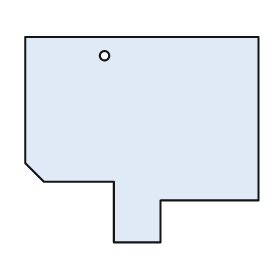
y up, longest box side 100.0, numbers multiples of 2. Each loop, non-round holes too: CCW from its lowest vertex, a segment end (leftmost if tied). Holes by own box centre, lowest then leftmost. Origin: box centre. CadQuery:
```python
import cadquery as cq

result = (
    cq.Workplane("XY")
    .moveTo(-12.0, -44.0)
    .lineTo(8.0, -44.0)
    .lineTo(8.0, -26.0)
    .lineTo(50.0, -26.0)
    .lineTo(50.0, 44.0)
    .lineTo(-50.0, 44.0)
    .lineTo(-50.0, -10.0)
    .lineTo(-42.0, -18.0)
    .lineTo(-12.0, -18.0)
    .close()
    .moveTo(-16.0, 36.0)
    .circle(2.0)
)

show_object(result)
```